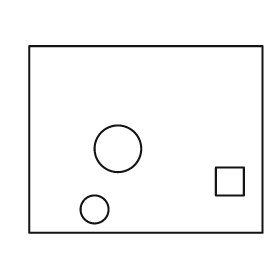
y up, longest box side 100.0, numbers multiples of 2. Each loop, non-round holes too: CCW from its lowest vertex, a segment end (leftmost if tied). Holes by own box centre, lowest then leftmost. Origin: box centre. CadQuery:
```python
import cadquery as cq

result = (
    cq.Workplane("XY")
    .moveTo(-50.0, -40.0)
    .lineTo(50.0, -40.0)
    .lineTo(50.0, 40.0)
    .lineTo(-50.0, 40.0)
    .close()
    .moveTo(-22.0, -30.0)
    .circle(6.0)
    .moveTo(30.0, -24.0)
    .lineTo(42.0, -24.0)
    .lineTo(42.0, -12.0)
    .lineTo(30.0, -12.0)
    .close()
    .moveTo(-12.0, -4.0)
    .circle(10.0)
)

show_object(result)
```